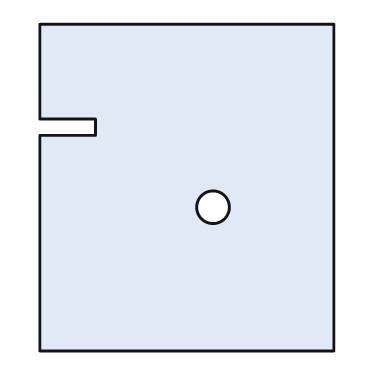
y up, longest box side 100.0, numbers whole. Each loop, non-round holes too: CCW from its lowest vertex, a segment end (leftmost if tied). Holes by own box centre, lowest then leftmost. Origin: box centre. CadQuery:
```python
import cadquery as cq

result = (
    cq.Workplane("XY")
    .moveTo(-45.0, -50.0)
    .lineTo(45.0, -50.0)
    .lineTo(45.0, 50.0)
    .lineTo(-45.0, 50.0)
    .lineTo(-45.0, 21.0)
    .lineTo(-28.0, 21.0)
    .lineTo(-28.0, 16.0)
    .lineTo(-45.0, 16.0)
    .close()
    .moveTo(8.0, -6.0)
    .circle(5.0)
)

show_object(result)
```